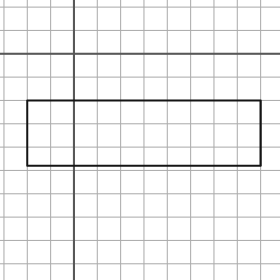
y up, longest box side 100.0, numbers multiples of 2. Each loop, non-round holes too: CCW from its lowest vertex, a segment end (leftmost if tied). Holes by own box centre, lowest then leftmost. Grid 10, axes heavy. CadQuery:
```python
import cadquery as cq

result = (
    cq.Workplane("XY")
    .moveTo(-20.0, -48.0)
    .lineTo(80.0, -48.0)
    .lineTo(80.0, -20.0)
    .lineTo(-20.0, -20.0)
    .close()
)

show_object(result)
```